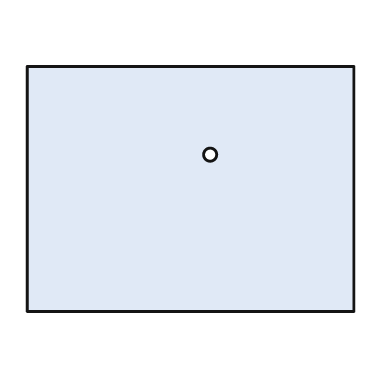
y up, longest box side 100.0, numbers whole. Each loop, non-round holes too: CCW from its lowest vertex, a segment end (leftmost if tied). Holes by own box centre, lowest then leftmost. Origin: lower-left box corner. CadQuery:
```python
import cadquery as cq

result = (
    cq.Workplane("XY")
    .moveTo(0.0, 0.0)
    .lineTo(100.0, 0.0)
    .lineTo(100.0, 75.0)
    .lineTo(0.0, 75.0)
    .close()
    .moveTo(56.0, 48.0)
    .circle(2.0)
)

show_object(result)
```